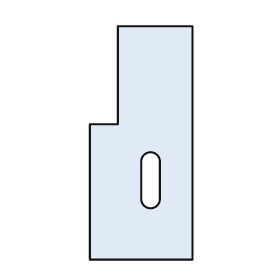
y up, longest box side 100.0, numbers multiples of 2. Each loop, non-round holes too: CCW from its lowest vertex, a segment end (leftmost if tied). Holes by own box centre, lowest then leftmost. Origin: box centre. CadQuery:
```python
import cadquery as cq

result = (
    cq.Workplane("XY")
    .moveTo(-22.0, -50.0)
    .lineTo(22.0, -50.0)
    .lineTo(22.0, 50.0)
    .lineTo(-10.0, 50.0)
    .lineTo(-10.0, 8.0)
    .lineTo(-22.0, 8.0)
    .close()
    .moveTo(0.0, -24.0)
    .threePointArc((4.0, -28.0), (8.0, -24.0))
    .lineTo(8.0, -8.0)
    .threePointArc((4.0, -4.0), (0.0, -8.0))
    .close()
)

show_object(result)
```